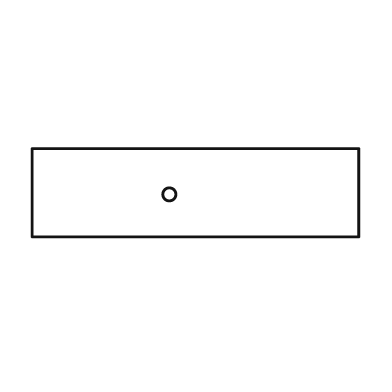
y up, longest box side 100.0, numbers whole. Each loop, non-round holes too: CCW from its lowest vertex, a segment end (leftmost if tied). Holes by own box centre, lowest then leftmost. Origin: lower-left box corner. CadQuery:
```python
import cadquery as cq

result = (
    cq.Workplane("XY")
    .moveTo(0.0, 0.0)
    .lineTo(100.0, 0.0)
    .lineTo(100.0, 27.0)
    .lineTo(0.0, 27.0)
    .close()
    .moveTo(42.0, 13.0)
    .circle(2.0)
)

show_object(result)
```